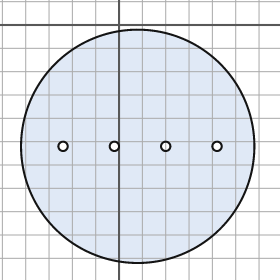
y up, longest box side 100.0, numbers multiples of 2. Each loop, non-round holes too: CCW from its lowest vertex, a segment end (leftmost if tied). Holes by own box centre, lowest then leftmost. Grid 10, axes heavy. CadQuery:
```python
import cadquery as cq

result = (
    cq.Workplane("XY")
    .moveTo(8.0, -52.0)
    .circle(50.0)
    .moveTo(-24.0, -52.0)
    .circle(2.0)
    .moveTo(-2.0, -52.0)
    .circle(2.0)
    .moveTo(20.0, -52.0)
    .circle(2.0)
    .moveTo(42.0, -52.0)
    .circle(2.0)
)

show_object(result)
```